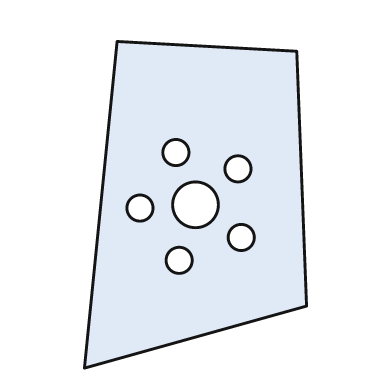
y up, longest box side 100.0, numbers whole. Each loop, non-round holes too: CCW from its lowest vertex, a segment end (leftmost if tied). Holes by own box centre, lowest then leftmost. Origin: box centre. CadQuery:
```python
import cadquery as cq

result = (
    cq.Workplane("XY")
    .moveTo(-34.0, -50.0)
    .lineTo(34.0, -31.0)
    .lineTo(31.0, 47.0)
    .lineTo(-24.0, 50.0)
    .close()
    .moveTo(-5.0, -17.0)
    .circle(4.0)
    .moveTo(14.0, -10.0)
    .circle(4.0)
    .moveTo(-17.0, -1.0)
    .circle(4.0)
    .moveTo(0.0, 0.0)
    .circle(7.0)
    .moveTo(13.0, 11.0)
    .circle(4.0)
    .moveTo(-6.0, 16.0)
    .circle(4.0)
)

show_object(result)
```